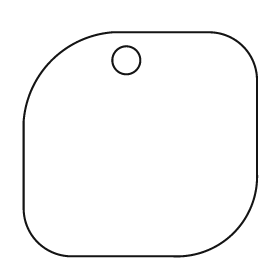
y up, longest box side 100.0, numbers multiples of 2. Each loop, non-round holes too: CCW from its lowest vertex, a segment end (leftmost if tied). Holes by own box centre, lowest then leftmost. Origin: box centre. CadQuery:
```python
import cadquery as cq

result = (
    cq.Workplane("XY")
    .moveTo(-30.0, -48.0)
    .lineTo(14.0, -48.0)
    .threePointArc((40.0, -38.0), (50.0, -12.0))
    .lineTo(50.0, 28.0)
    .threePointArc((44.0, 42.0), (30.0, 48.0))
    .lineTo(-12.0, 48.0)
    .threePointArc((-38.0, 36.0), (-50.0, 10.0))
    .lineTo(-50.0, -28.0)
    .threePointArc((-44.0, -42.0), (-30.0, -48.0))
    .close()
    .moveTo(-6.0, 36.0)
    .circle(6.0)
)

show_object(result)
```